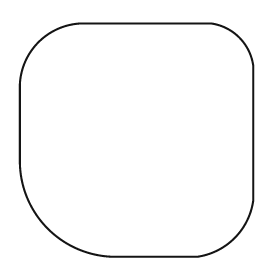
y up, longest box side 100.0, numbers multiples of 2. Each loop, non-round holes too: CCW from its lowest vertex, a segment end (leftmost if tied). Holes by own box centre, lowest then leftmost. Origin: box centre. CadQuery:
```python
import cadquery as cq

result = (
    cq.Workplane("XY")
    .moveTo(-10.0, -50.0)
    .lineTo(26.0, -50.0)
    .threePointArc((42.0, -42.0), (50.0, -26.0))
    .lineTo(50.0, 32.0)
    .threePointArc((44.0, 44.0), (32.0, 50.0))
    .lineTo(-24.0, 50.0)
    .threePointArc((-42.0, 42.0), (-50.0, 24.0))
    .lineTo(-50.0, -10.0)
    .threePointArc((-38.0, -38.0), (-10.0, -50.0))
    .close()
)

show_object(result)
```